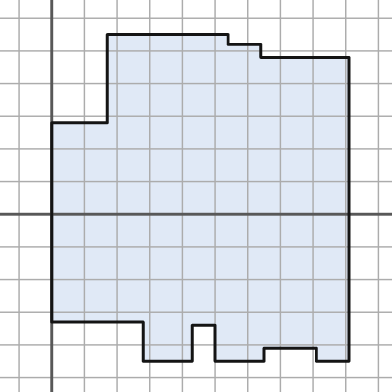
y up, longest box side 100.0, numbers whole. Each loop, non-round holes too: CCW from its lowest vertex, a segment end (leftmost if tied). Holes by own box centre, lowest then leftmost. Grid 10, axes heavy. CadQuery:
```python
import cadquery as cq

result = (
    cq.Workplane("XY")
    .moveTo(28.0, -45.0)
    .lineTo(43.0, -45.0)
    .lineTo(43.0, -34.0)
    .lineTo(50.0, -34.0)
    .lineTo(50.0, -45.0)
    .lineTo(65.0, -45.0)
    .lineTo(65.0, -41.0)
    .lineTo(81.0, -41.0)
    .lineTo(81.0, -45.0)
    .lineTo(91.0, -45.0)
    .lineTo(91.0, 48.0)
    .lineTo(64.0, 48.0)
    .lineTo(64.0, 52.0)
    .lineTo(54.0, 52.0)
    .lineTo(54.0, 55.0)
    .lineTo(17.0, 55.0)
    .lineTo(17.0, 28.0)
    .lineTo(0.0, 28.0)
    .lineTo(0.0, -33.0)
    .lineTo(28.0, -33.0)
    .close()
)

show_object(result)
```